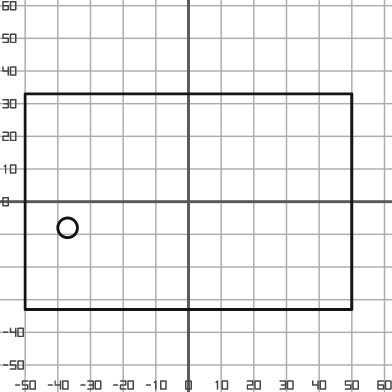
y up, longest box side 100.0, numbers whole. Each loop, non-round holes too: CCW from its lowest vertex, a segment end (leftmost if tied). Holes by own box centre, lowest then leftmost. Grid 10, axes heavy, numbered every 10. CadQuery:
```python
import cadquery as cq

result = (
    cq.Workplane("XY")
    .moveTo(-50.0, -33.0)
    .lineTo(50.0, -33.0)
    .lineTo(50.0, 33.0)
    .lineTo(-50.0, 33.0)
    .close()
    .moveTo(-37.0, -8.0)
    .circle(3.0)
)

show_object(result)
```